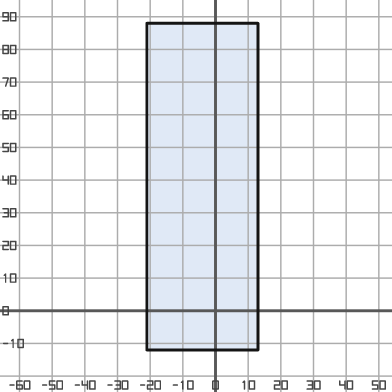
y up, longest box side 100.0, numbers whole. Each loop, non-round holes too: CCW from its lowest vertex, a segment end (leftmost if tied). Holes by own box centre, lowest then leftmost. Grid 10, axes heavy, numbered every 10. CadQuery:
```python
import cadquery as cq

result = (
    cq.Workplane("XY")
    .moveTo(-21.0, -12.0)
    .lineTo(13.0, -12.0)
    .lineTo(13.0, 88.0)
    .lineTo(-21.0, 88.0)
    .close()
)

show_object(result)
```